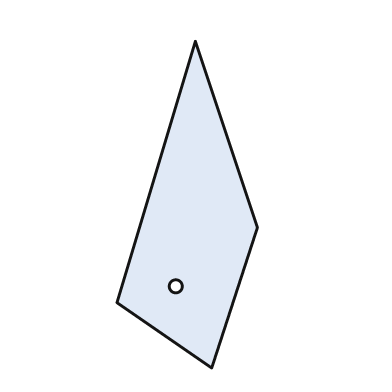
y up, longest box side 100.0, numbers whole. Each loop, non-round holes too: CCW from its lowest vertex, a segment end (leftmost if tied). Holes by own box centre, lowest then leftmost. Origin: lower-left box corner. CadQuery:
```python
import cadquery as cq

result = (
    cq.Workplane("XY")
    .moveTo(29.0, 0.0)
    .lineTo(43.0, 43.0)
    .lineTo(24.0, 100.0)
    .lineTo(0.0, 20.0)
    .close()
    .moveTo(18.0, 25.0)
    .circle(2.0)
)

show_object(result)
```